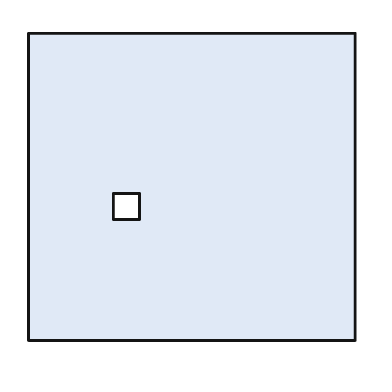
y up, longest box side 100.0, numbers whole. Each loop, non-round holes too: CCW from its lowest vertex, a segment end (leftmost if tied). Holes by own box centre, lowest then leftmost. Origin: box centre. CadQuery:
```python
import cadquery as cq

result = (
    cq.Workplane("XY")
    .moveTo(-50.0, -47.0)
    .lineTo(50.0, -47.0)
    .lineTo(50.0, 47.0)
    .lineTo(-50.0, 47.0)
    .close()
    .moveTo(-24.0, -10.0)
    .lineTo(-16.0, -10.0)
    .lineTo(-16.0, -2.0)
    .lineTo(-24.0, -2.0)
    .close()
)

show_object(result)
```